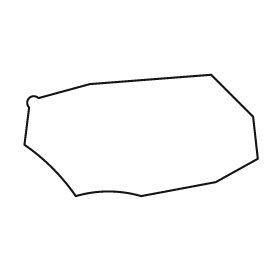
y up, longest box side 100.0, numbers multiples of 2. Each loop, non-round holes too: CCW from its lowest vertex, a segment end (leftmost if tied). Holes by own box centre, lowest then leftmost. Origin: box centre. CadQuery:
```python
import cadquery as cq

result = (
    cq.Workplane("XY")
    .moveTo(-28.0, -26.0)
    .threePointArc((-14.0, -24.0), (0.0, -26.0))
    .lineTo(32.0, -20.0)
    .lineTo(50.0, -10.0)
    .lineTo(48.0, 8.0)
    .lineTo(30.0, 26.0)
    .lineTo(-22.0, 22.0)
    .lineTo(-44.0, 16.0)
    .threePointArc((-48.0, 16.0), (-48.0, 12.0))
    .lineTo(-50.0, -4.0)
    .threePointArc((-38.0, -14.0), (-28.0, -26.0))
    .close()
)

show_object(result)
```